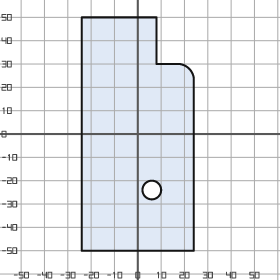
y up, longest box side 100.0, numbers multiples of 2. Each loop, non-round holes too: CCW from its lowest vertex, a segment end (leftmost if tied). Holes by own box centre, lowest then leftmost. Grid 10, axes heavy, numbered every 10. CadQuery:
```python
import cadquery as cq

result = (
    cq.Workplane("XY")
    .moveTo(-24.0, -50.0)
    .lineTo(24.0, -50.0)
    .lineTo(24.0, 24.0)
    .threePointArc((22.0, 28.0), (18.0, 30.0))
    .lineTo(8.0, 30.0)
    .lineTo(8.0, 50.0)
    .lineTo(-24.0, 50.0)
    .close()
    .moveTo(6.0, -24.0)
    .circle(4.0)
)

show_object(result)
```